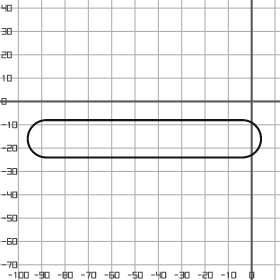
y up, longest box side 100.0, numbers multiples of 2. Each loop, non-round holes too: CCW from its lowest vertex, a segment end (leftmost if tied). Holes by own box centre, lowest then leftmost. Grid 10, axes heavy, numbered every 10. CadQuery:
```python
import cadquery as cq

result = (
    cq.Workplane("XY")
    .moveTo(-88.0, -24.0)
    .lineTo(-4.0, -24.0)
    .threePointArc((4.0, -16.0), (-4.0, -8.0))
    .lineTo(-88.0, -8.0)
    .threePointArc((-96.0, -16.0), (-88.0, -24.0))
    .close()
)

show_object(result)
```